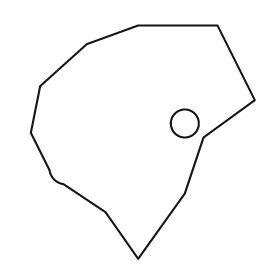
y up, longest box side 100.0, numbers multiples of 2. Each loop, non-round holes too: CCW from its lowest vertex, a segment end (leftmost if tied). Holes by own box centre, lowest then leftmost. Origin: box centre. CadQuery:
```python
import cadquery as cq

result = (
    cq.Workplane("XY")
    .moveTo(-2.0, -50.0)
    .lineTo(18.0, -22.0)
    .lineTo(26.0, 2.0)
    .lineTo(48.0, 18.0)
    .lineTo(32.0, 50.0)
    .lineTo(-2.0, 50.0)
    .lineTo(-24.0, 42.0)
    .lineTo(-44.0, 24.0)
    .lineTo(-48.0, 4.0)
    .lineTo(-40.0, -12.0)
    .threePointArc((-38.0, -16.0), (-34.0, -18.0))
    .lineTo(-16.0, -30.0)
    .close()
    .moveTo(18.0, 8.0)
    .circle(6.0)
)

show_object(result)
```